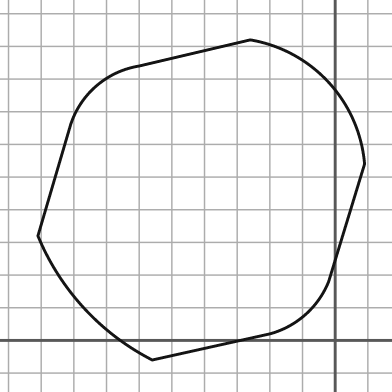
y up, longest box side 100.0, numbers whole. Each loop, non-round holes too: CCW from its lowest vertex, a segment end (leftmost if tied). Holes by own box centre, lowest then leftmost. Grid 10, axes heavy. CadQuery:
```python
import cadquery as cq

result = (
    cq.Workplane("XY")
    .moveTo(-56.0, -6.0)
    .lineTo(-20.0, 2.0)
    .threePointArc((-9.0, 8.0), (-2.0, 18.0))
    .lineTo(9.0, 54.0)
    .threePointArc((-2.0, 79.0), (-26.0, 92.0))
    .lineTo(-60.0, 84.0)
    .threePointArc((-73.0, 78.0), (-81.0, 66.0))
    .lineTo(-91.0, 32.0)
    .threePointArc((-77.0, 10.0), (-56.0, -6.0))
    .close()
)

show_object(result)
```